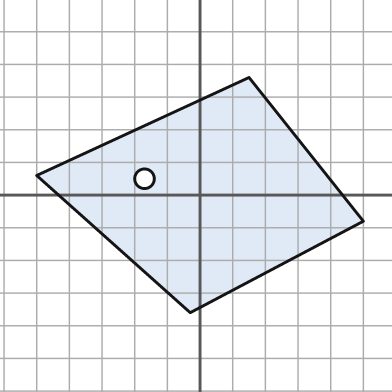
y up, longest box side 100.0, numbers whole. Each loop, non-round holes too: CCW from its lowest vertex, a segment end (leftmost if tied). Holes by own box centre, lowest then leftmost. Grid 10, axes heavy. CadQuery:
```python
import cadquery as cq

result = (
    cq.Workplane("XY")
    .moveTo(-3.0, -36.0)
    .lineTo(50.0, -8.0)
    .lineTo(15.0, 36.0)
    .lineTo(-50.0, 6.0)
    .close()
    .moveTo(-17.0, 5.0)
    .circle(3.0)
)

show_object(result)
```